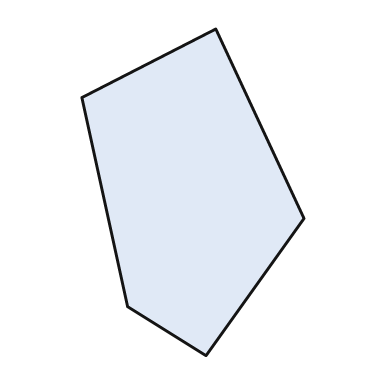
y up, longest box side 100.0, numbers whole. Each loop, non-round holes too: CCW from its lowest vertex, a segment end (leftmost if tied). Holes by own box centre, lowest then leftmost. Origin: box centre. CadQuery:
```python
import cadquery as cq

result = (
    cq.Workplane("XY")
    .moveTo(4.0, -50.0)
    .lineTo(34.0, -8.0)
    .lineTo(7.0, 50.0)
    .lineTo(-34.0, 29.0)
    .lineTo(-20.0, -35.0)
    .close()
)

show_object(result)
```